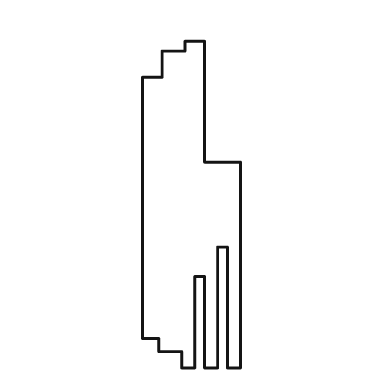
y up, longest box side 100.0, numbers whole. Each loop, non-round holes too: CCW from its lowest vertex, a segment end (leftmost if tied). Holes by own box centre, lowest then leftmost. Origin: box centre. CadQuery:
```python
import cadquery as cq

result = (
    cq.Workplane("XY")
    .moveTo(-3.0, -50.0)
    .lineTo(1.0, -50.0)
    .lineTo(1.0, -22.0)
    .lineTo(4.0, -22.0)
    .lineTo(4.0, -50.0)
    .lineTo(8.0, -50.0)
    .lineTo(8.0, -13.0)
    .lineTo(11.0, -13.0)
    .lineTo(11.0, -50.0)
    .lineTo(15.0, -50.0)
    .lineTo(15.0, 13.0)
    .lineTo(4.0, 13.0)
    .lineTo(4.0, 50.0)
    .lineTo(-2.0, 50.0)
    .lineTo(-2.0, 47.0)
    .lineTo(-9.0, 47.0)
    .lineTo(-9.0, 39.0)
    .lineTo(-15.0, 39.0)
    .lineTo(-15.0, -41.0)
    .lineTo(-10.0, -41.0)
    .lineTo(-10.0, -45.0)
    .lineTo(-3.0, -45.0)
    .close()
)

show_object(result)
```